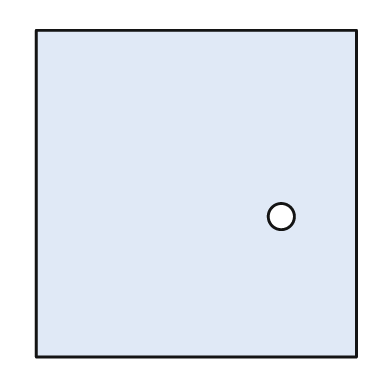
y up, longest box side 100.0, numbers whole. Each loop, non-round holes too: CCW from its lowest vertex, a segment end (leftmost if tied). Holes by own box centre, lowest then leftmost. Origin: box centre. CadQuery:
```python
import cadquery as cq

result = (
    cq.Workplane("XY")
    .moveTo(-49.0, -50.0)
    .lineTo(49.0, -50.0)
    .lineTo(49.0, 50.0)
    .lineTo(-49.0, 50.0)
    .close()
    .moveTo(26.0, -7.0)
    .circle(4.0)
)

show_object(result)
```